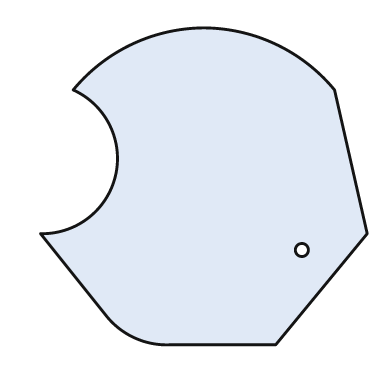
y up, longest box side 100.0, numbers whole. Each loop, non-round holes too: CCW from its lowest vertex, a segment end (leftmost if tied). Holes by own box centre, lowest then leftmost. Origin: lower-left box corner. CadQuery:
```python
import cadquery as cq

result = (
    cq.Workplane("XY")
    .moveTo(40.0, 0.0)
    .lineTo(72.0, 0.0)
    .lineTo(100.0, 34.0)
    .lineTo(90.0, 78.0)
    .threePointArc((72.0, 92.0), (50.0, 97.0))
    .threePointArc((28.0, 92.0), (10.0, 78.0))
    .threePointArc((23.0, 52.0), (0.0, 34.0))
    .lineTo(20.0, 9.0)
    .threePointArc((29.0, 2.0), (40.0, 0.0))
    .close()
    .moveTo(80.0, 29.0)
    .circle(2.0)
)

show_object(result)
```